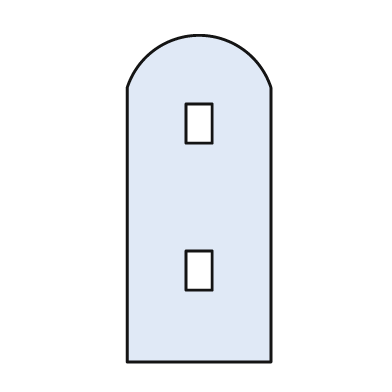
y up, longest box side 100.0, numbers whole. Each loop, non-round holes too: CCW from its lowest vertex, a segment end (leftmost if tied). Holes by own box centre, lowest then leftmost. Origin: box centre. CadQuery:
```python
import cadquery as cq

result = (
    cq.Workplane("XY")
    .moveTo(-22.0, -50.0)
    .lineTo(22.0, -50.0)
    .lineTo(22.0, 34.0)
    .threePointArc((0.0, 50.0), (-22.0, 34.0))
    .close()
    .moveTo(-4.0, -28.0)
    .lineTo(4.0, -28.0)
    .lineTo(4.0, -16.0)
    .lineTo(-4.0, -16.0)
    .close()
    .moveTo(-4.0, 17.0)
    .lineTo(4.0, 17.0)
    .lineTo(4.0, 29.0)
    .lineTo(-4.0, 29.0)
    .close()
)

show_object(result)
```